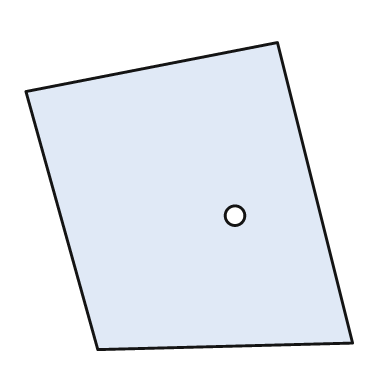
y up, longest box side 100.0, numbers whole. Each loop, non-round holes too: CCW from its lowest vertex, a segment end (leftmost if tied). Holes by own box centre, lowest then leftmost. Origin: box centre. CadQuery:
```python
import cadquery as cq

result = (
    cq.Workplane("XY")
    .moveTo(-28.0, -47.0)
    .lineTo(50.0, -45.0)
    .lineTo(27.0, 47.0)
    .lineTo(-50.0, 32.0)
    .close()
    .moveTo(14.0, -6.0)
    .circle(3.0)
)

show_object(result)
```